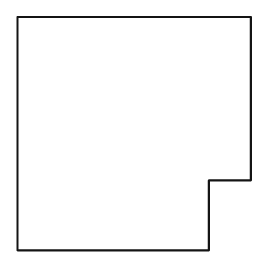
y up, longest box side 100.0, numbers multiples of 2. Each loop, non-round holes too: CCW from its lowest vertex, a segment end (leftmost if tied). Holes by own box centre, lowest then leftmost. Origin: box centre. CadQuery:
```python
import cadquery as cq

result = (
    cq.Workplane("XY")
    .moveTo(-50.0, -50.0)
    .lineTo(32.0, -50.0)
    .lineTo(32.0, -20.0)
    .lineTo(50.0, -20.0)
    .lineTo(50.0, 50.0)
    .lineTo(-50.0, 50.0)
    .close()
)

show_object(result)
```